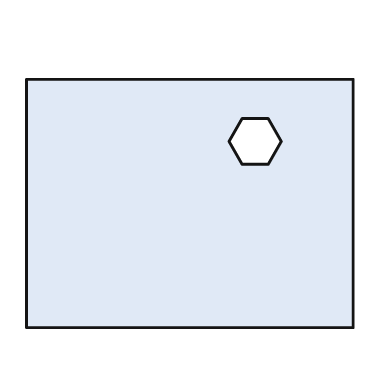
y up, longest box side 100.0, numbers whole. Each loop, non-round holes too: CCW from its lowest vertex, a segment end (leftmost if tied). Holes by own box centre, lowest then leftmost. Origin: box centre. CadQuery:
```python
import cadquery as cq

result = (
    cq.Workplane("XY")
    .moveTo(-50.0, -38.0)
    .lineTo(50.0, -38.0)
    .lineTo(50.0, 38.0)
    .lineTo(-50.0, 38.0)
    .close()
    .moveTo(16.0, 12.0)
    .lineTo(24.0, 12.0)
    .lineTo(28.0, 19.0)
    .lineTo(24.0, 26.0)
    .lineTo(16.0, 26.0)
    .lineTo(12.0, 19.0)
    .close()
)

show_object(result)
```